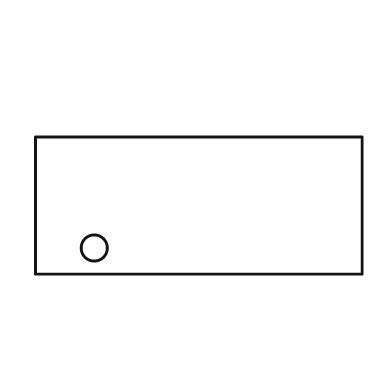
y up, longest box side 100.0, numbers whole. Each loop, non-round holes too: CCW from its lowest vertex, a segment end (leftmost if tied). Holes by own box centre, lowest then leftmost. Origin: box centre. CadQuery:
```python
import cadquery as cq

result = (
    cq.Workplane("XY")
    .moveTo(-50.0, -21.0)
    .lineTo(50.0, -21.0)
    .lineTo(50.0, 21.0)
    .lineTo(-50.0, 21.0)
    .close()
    .moveTo(-32.0, -13.0)
    .circle(4.0)
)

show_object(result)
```